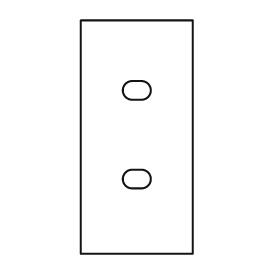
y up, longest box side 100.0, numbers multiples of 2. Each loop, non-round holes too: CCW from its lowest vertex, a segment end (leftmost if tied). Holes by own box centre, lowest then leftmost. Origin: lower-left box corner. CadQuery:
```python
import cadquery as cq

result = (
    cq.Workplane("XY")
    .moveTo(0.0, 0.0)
    .lineTo(48.0, 0.0)
    .lineTo(48.0, 100.0)
    .lineTo(0.0, 100.0)
    .close()
    .moveTo(22.0, 28.0)
    .lineTo(26.0, 28.0)
    .threePointArc((30.0, 32.0), (26.0, 36.0))
    .lineTo(22.0, 36.0)
    .threePointArc((18.0, 32.0), (22.0, 28.0))
    .close()
    .moveTo(22.0, 66.0)
    .lineTo(26.0, 66.0)
    .threePointArc((30.0, 70.0), (26.0, 74.0))
    .lineTo(22.0, 74.0)
    .threePointArc((18.0, 70.0), (22.0, 66.0))
    .close()
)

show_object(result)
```